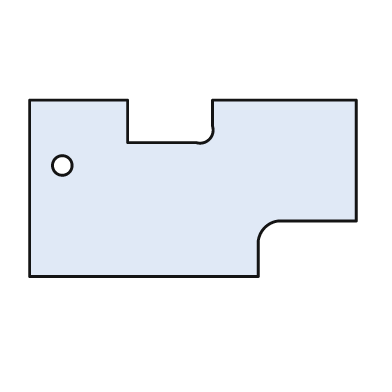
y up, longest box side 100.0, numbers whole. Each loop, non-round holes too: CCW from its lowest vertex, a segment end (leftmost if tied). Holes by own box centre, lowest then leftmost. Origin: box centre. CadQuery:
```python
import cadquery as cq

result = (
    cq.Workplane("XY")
    .moveTo(-50.0, -27.0)
    .lineTo(20.0, -27.0)
    .lineTo(20.0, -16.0)
    .threePointArc((22.0, -12.0), (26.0, -10.0))
    .lineTo(50.0, -10.0)
    .lineTo(50.0, 27.0)
    .lineTo(6.0, 27.0)
    .lineTo(6.0, 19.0)
    .threePointArc((5.0, 15.0), (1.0, 14.0))
    .lineTo(-20.0, 14.0)
    .lineTo(-20.0, 27.0)
    .lineTo(-50.0, 27.0)
    .close()
    .moveTo(-40.0, 7.0)
    .circle(3.0)
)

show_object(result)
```